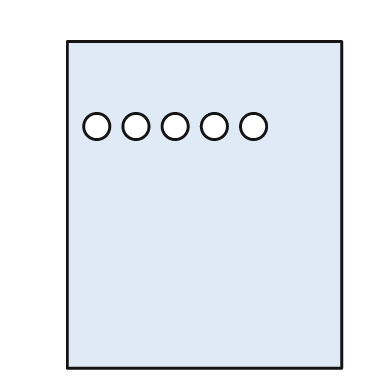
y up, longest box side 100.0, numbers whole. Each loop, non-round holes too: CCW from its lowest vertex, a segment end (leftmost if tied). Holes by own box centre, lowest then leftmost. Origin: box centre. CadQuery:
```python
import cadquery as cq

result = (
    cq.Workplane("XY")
    .moveTo(-42.0, -50.0)
    .lineTo(42.0, -50.0)
    .lineTo(42.0, 50.0)
    .lineTo(-42.0, 50.0)
    .close()
    .moveTo(-33.0, 24.0)
    .circle(4.0)
    .moveTo(-21.0, 24.0)
    .circle(4.0)
    .moveTo(-9.0, 24.0)
    .circle(4.0)
    .moveTo(3.0, 24.0)
    .circle(4.0)
    .moveTo(15.0, 24.0)
    .circle(4.0)
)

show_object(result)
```